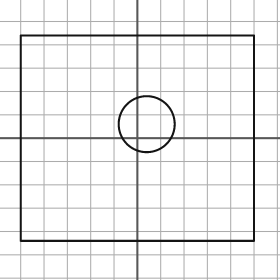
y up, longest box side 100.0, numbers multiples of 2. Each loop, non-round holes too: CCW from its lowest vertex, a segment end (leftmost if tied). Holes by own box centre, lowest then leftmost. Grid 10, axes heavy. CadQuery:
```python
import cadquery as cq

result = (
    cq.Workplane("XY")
    .moveTo(-50.0, -44.0)
    .lineTo(50.0, -44.0)
    .lineTo(50.0, 44.0)
    .lineTo(-50.0, 44.0)
    .close()
    .moveTo(4.0, 6.0)
    .circle(12.0)
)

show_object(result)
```